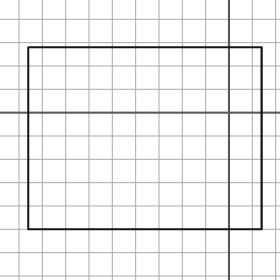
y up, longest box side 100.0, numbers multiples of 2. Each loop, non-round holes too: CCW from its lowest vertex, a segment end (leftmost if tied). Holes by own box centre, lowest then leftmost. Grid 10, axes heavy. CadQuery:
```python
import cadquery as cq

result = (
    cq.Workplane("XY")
    .moveTo(-86.0, -50.0)
    .lineTo(14.0, -50.0)
    .lineTo(14.0, 28.0)
    .lineTo(-86.0, 28.0)
    .close()
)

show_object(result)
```